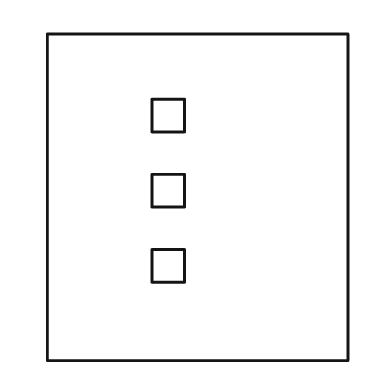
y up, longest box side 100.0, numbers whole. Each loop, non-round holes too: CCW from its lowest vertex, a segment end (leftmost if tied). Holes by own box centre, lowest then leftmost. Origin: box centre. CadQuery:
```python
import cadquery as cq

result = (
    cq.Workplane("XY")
    .moveTo(-46.0, -50.0)
    .lineTo(46.0, -50.0)
    .lineTo(46.0, 50.0)
    .lineTo(-46.0, 50.0)
    .close()
    .moveTo(-14.0, -26.0)
    .lineTo(-4.0, -26.0)
    .lineTo(-4.0, -16.0)
    .lineTo(-14.0, -16.0)
    .close()
    .moveTo(-14.0, -3.0)
    .lineTo(-4.0, -3.0)
    .lineTo(-4.0, 7.0)
    .lineTo(-14.0, 7.0)
    .close()
    .moveTo(-14.0, 20.0)
    .lineTo(-4.0, 20.0)
    .lineTo(-4.0, 30.0)
    .lineTo(-14.0, 30.0)
    .close()
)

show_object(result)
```